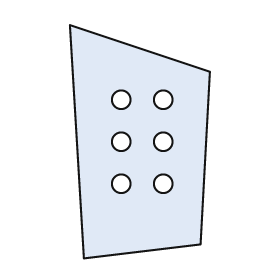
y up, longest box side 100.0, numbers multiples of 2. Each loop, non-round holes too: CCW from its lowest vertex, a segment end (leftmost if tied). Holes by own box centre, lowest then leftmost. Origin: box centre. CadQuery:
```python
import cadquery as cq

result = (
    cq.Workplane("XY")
    .moveTo(-24.0, -50.0)
    .lineTo(26.0, -44.0)
    .lineTo(30.0, 30.0)
    .lineTo(-30.0, 50.0)
    .close()
    .moveTo(-8.0, -18.0)
    .circle(4.0)
    .moveTo(10.0, -18.0)
    .circle(4.0)
    .moveTo(-8.0, 0.0)
    .circle(4.0)
    .moveTo(10.0, 0.0)
    .circle(4.0)
    .moveTo(-8.0, 18.0)
    .circle(4.0)
    .moveTo(10.0, 18.0)
    .circle(4.0)
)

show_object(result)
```